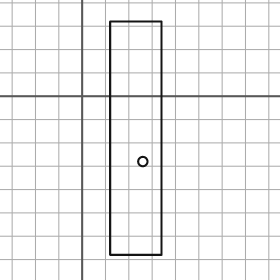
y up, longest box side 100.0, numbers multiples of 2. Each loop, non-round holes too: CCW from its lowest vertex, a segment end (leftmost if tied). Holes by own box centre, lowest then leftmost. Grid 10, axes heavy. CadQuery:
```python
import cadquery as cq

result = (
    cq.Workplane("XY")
    .moveTo(12.0, -68.0)
    .lineTo(34.0, -68.0)
    .lineTo(34.0, 32.0)
    .lineTo(12.0, 32.0)
    .close()
    .moveTo(26.0, -28.0)
    .circle(2.0)
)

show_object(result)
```